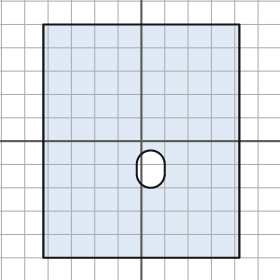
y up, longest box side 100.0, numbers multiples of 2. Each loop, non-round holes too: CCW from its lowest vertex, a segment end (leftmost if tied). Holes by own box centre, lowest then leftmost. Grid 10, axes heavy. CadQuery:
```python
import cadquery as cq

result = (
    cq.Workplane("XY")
    .moveTo(-42.0, -50.0)
    .lineTo(42.0, -50.0)
    .lineTo(42.0, 50.0)
    .lineTo(-42.0, 50.0)
    .close()
    .moveTo(-2.0, -14.0)
    .threePointArc((4.0, -20.0), (10.0, -14.0))
    .lineTo(10.0, -10.0)
    .threePointArc((4.0, -4.0), (-2.0, -10.0))
    .close()
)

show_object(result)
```